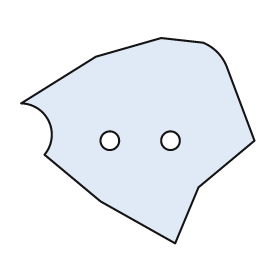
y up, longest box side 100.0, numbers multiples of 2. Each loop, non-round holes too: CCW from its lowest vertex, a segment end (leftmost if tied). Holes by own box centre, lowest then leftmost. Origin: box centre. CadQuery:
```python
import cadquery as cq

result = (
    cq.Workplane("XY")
    .moveTo(16.0, -44.0)
    .lineTo(26.0, -20.0)
    .lineTo(50.0, 0.0)
    .lineTo(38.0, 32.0)
    .threePointArc((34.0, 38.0), (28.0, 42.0))
    .lineTo(10.0, 44.0)
    .lineTo(-18.0, 36.0)
    .lineTo(-50.0, 16.0)
    .threePointArc((-38.0, 8.0), (-40.0, -6.0))
    .lineTo(-16.0, -26.0)
    .close()
    .moveTo(-12.0, 0.0)
    .circle(4.0)
    .moveTo(14.0, 0.0)
    .circle(4.0)
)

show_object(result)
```